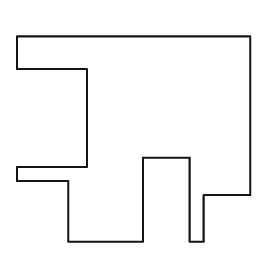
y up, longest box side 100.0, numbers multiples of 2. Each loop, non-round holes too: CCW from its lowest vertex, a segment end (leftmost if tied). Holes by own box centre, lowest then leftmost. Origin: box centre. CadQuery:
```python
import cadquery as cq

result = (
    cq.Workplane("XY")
    .moveTo(-28.0, -44.0)
    .lineTo(4.0, -44.0)
    .lineTo(4.0, -8.0)
    .lineTo(24.0, -8.0)
    .lineTo(24.0, -44.0)
    .lineTo(30.0, -44.0)
    .lineTo(30.0, -24.0)
    .lineTo(50.0, -24.0)
    .lineTo(50.0, 44.0)
    .lineTo(-50.0, 44.0)
    .lineTo(-50.0, 30.0)
    .lineTo(-20.0, 30.0)
    .lineTo(-20.0, -12.0)
    .lineTo(-50.0, -12.0)
    .lineTo(-50.0, -18.0)
    .lineTo(-28.0, -18.0)
    .close()
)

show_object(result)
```